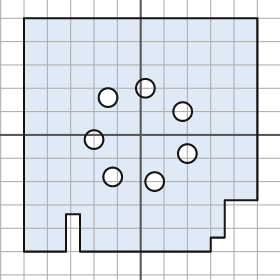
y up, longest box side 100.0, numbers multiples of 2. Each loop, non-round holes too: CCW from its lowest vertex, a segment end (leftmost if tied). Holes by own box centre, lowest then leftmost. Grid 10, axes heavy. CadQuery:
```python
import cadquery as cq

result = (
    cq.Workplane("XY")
    .moveTo(-50.0, -50.0)
    .lineTo(-32.0, -50.0)
    .lineTo(-32.0, -34.0)
    .lineTo(-26.0, -34.0)
    .lineTo(-26.0, -50.0)
    .lineTo(30.0, -50.0)
    .lineTo(30.0, -44.0)
    .lineTo(36.0, -44.0)
    .lineTo(36.0, -28.0)
    .lineTo(50.0, -28.0)
    .lineTo(50.0, 50.0)
    .lineTo(-50.0, 50.0)
    .close()
    .moveTo(6.0, -20.0)
    .circle(4.0)
    .moveTo(-12.0, -18.0)
    .circle(4.0)
    .moveTo(20.0, -8.0)
    .circle(4.0)
    .moveTo(-20.0, -2.0)
    .circle(4.0)
    .moveTo(18.0, 10.0)
    .circle(4.0)
    .moveTo(-14.0, 16.0)
    .circle(4.0)
    .moveTo(2.0, 20.0)
    .circle(4.0)
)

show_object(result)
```